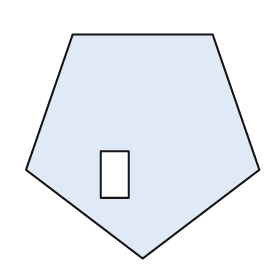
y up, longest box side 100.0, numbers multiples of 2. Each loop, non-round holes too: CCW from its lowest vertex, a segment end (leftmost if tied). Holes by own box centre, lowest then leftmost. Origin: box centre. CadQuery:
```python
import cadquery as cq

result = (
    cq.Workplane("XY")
    .moveTo(0.0, -48.0)
    .lineTo(50.0, -10.0)
    .lineTo(30.0, 48.0)
    .lineTo(-30.0, 48.0)
    .lineTo(-50.0, -10.0)
    .close()
    .moveTo(-18.0, -22.0)
    .lineTo(-6.0, -22.0)
    .lineTo(-6.0, -2.0)
    .lineTo(-18.0, -2.0)
    .close()
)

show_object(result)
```